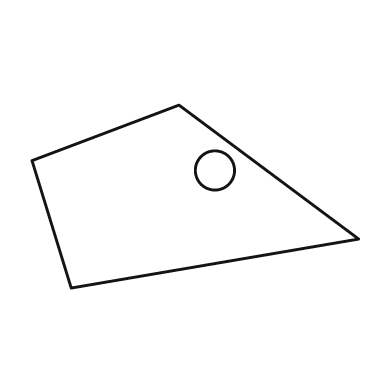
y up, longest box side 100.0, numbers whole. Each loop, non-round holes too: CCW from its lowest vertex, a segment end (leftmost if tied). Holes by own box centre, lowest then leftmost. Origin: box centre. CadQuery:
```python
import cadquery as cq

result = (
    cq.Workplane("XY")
    .moveTo(-38.0, -28.0)
    .lineTo(50.0, -13.0)
    .lineTo(-5.0, 28.0)
    .lineTo(-50.0, 11.0)
    .close()
    .moveTo(6.0, 8.0)
    .circle(6.0)
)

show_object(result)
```